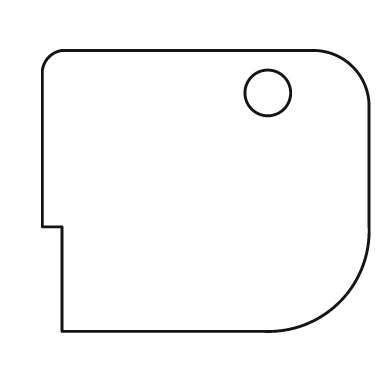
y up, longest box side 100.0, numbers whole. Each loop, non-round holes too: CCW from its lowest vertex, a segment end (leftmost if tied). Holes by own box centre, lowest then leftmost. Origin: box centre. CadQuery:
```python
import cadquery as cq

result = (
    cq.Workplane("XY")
    .moveTo(-44.0, -43.0)
    .lineTo(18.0, -43.0)
    .threePointArc((41.0, -34.0), (50.0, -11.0))
    .lineTo(50.0, 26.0)
    .threePointArc((45.0, 38.0), (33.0, 43.0))
    .lineTo(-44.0, 43.0)
    .threePointArc((-48.0, 41.0), (-50.0, 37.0))
    .lineTo(-50.0, -11.0)
    .lineTo(-44.0, -11.0)
    .close()
    .moveTo(19.0, 30.0)
    .circle(7.0)
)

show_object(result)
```